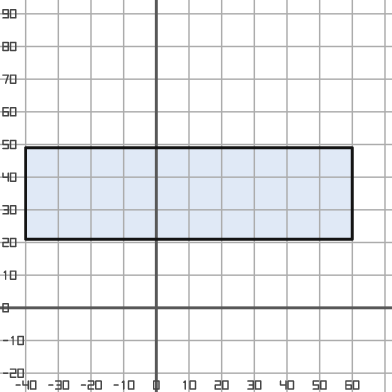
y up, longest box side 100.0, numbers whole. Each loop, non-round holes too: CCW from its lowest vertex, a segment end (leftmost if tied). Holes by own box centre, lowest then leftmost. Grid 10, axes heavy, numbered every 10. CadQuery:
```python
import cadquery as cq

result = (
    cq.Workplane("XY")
    .moveTo(-40.0, 21.0)
    .lineTo(60.0, 21.0)
    .lineTo(60.0, 49.0)
    .lineTo(-40.0, 49.0)
    .close()
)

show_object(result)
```